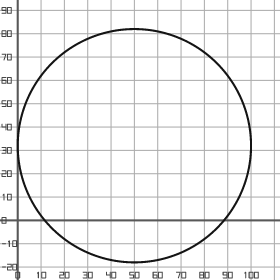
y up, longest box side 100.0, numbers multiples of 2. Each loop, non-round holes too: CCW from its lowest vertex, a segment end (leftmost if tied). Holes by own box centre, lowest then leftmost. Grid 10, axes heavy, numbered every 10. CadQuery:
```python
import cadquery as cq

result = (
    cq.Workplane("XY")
    .moveTo(50.0, 32.0)
    .circle(50.0)
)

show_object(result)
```